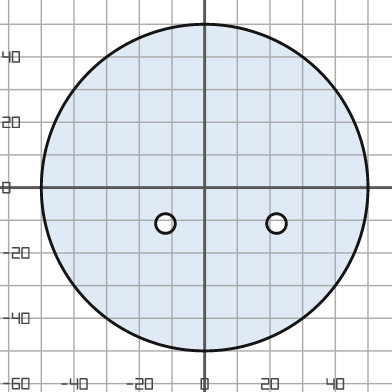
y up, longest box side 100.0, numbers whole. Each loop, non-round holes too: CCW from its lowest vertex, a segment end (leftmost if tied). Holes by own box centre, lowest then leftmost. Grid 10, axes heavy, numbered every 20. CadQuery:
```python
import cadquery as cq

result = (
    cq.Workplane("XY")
    .moveTo(0.0, 0.0)
    .circle(50.0)
    .moveTo(-12.0, -11.0)
    .circle(3.0)
    .moveTo(22.0, -11.0)
    .circle(3.0)
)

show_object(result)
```